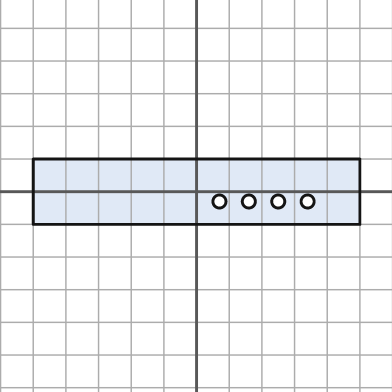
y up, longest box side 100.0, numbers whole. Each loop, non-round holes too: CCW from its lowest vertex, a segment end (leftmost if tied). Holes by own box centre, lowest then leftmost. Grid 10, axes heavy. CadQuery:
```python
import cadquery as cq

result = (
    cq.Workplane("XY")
    .moveTo(-50.0, -10.0)
    .lineTo(50.0, -10.0)
    .lineTo(50.0, 10.0)
    .lineTo(-50.0, 10.0)
    .close()
    .moveTo(7.0, -3.0)
    .circle(2.0)
    .moveTo(16.0, -3.0)
    .circle(2.0)
    .moveTo(25.0, -3.0)
    .circle(2.0)
    .moveTo(34.0, -3.0)
    .circle(2.0)
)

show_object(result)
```